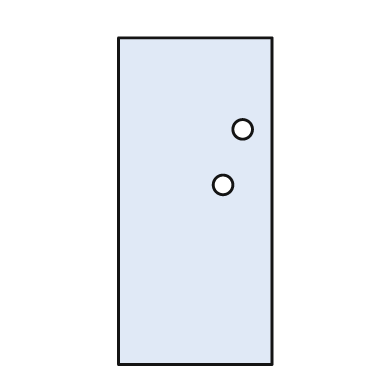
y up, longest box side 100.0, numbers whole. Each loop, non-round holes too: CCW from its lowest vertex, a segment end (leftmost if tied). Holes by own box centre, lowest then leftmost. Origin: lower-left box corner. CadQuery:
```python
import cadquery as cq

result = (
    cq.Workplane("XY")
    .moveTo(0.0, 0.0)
    .lineTo(47.0, 0.0)
    .lineTo(47.0, 100.0)
    .lineTo(0.0, 100.0)
    .close()
    .moveTo(32.0, 55.0)
    .circle(3.0)
    .moveTo(38.0, 72.0)
    .circle(3.0)
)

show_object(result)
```